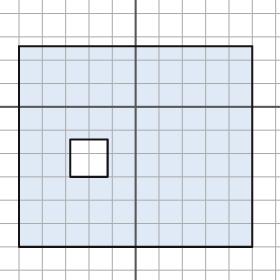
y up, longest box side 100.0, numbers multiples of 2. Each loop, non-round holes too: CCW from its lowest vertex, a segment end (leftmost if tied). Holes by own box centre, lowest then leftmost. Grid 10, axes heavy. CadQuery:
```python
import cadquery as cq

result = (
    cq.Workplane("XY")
    .moveTo(-50.0, -60.0)
    .lineTo(50.0, -60.0)
    .lineTo(50.0, 26.0)
    .lineTo(-50.0, 26.0)
    .close()
    .moveTo(-28.0, -30.0)
    .lineTo(-12.0, -30.0)
    .lineTo(-12.0, -14.0)
    .lineTo(-28.0, -14.0)
    .close()
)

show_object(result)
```